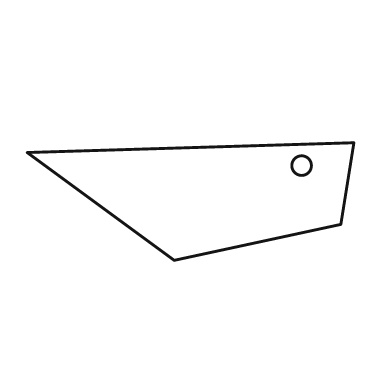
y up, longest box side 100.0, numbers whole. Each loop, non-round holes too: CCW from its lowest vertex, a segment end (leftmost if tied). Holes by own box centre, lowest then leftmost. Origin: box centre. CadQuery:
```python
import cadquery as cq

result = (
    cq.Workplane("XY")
    .moveTo(-5.0, -18.0)
    .lineTo(46.0, -7.0)
    .lineTo(50.0, 18.0)
    .lineTo(-50.0, 15.0)
    .close()
    .moveTo(34.0, 11.0)
    .circle(3.0)
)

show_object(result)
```